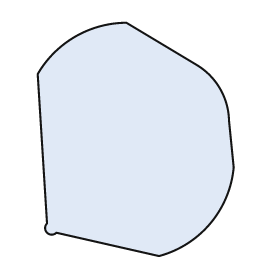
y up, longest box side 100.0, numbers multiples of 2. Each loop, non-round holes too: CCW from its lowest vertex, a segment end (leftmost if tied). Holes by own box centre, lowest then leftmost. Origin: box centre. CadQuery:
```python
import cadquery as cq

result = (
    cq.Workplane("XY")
    .moveTo(10.0, -50.0)
    .threePointArc((32.0, -36.0), (42.0, -12.0))
    .lineTo(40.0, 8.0)
    .threePointArc((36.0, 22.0), (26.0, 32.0))
    .lineTo(-4.0, 50.0)
    .threePointArc((-26.0, 44.0), (-42.0, 28.0))
    .lineTo(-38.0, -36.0)
    .threePointArc((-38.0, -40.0), (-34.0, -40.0))
    .close()
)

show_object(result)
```